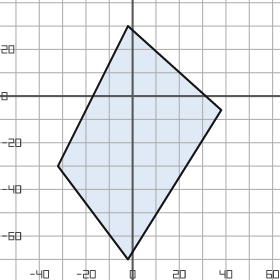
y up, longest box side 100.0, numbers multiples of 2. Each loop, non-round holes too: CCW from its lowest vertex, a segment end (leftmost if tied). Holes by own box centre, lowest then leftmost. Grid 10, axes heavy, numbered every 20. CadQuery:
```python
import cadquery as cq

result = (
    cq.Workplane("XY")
    .moveTo(-2.0, -70.0)
    .lineTo(38.0, -6.0)
    .lineTo(-2.0, 30.0)
    .lineTo(-32.0, -30.0)
    .close()
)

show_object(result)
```